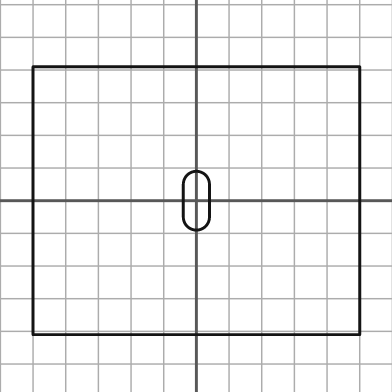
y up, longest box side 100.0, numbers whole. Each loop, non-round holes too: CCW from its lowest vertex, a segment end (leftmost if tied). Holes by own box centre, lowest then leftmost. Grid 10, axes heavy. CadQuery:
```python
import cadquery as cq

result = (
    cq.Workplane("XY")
    .moveTo(-50.0, -41.0)
    .lineTo(50.0, -41.0)
    .lineTo(50.0, 41.0)
    .lineTo(-50.0, 41.0)
    .close()
    .moveTo(-4.0, -5.0)
    .threePointArc((0.0, -9.0), (4.0, -5.0))
    .lineTo(4.0, 5.0)
    .threePointArc((0.0, 9.0), (-4.0, 5.0))
    .close()
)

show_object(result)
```